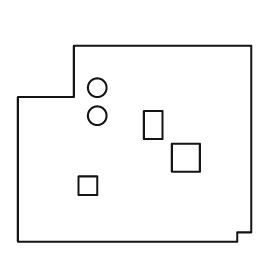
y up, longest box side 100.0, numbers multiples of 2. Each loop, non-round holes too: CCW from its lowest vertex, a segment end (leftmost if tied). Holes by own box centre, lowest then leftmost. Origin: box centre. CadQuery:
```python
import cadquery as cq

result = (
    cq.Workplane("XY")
    .moveTo(-50.0, -42.0)
    .lineTo(44.0, -42.0)
    .lineTo(44.0, -38.0)
    .lineTo(50.0, -38.0)
    .lineTo(50.0, 42.0)
    .lineTo(-26.0, 42.0)
    .lineTo(-26.0, 20.0)
    .lineTo(-50.0, 20.0)
    .close()
    .moveTo(-24.0, -22.0)
    .lineTo(-16.0, -22.0)
    .lineTo(-16.0, -14.0)
    .lineTo(-24.0, -14.0)
    .close()
    .moveTo(16.0, -12.0)
    .lineTo(28.0, -12.0)
    .lineTo(28.0, 0.0)
    .lineTo(16.0, 0.0)
    .close()
    .moveTo(4.0, 2.0)
    .lineTo(12.0, 2.0)
    .lineTo(12.0, 14.0)
    .lineTo(4.0, 14.0)
    .close()
    .moveTo(-16.0, 12.0)
    .circle(4.0)
    .moveTo(-16.0, 24.0)
    .circle(4.0)
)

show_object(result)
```